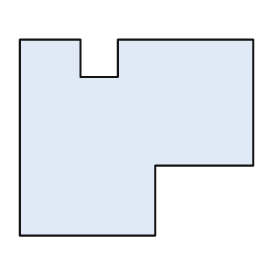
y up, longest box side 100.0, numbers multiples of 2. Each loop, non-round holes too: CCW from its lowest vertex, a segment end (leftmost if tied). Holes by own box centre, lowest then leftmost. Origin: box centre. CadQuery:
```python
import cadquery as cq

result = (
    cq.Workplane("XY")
    .moveTo(-50.0, -42.0)
    .lineTo(8.0, -42.0)
    .lineTo(8.0, -12.0)
    .lineTo(50.0, -12.0)
    .lineTo(50.0, 42.0)
    .lineTo(-8.0, 42.0)
    .lineTo(-8.0, 26.0)
    .lineTo(-24.0, 26.0)
    .lineTo(-24.0, 42.0)
    .lineTo(-50.0, 42.0)
    .close()
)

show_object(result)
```